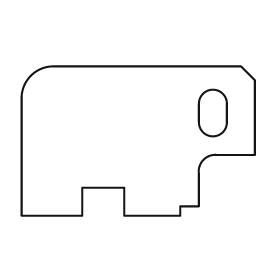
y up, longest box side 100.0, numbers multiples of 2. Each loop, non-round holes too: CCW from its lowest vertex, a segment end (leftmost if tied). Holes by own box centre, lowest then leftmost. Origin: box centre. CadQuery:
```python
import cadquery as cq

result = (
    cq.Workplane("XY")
    .moveTo(-50.0, -32.0)
    .lineTo(-24.0, -32.0)
    .lineTo(-24.0, -20.0)
    .lineTo(-6.0, -20.0)
    .lineTo(-6.0, -32.0)
    .lineTo(18.0, -32.0)
    .lineTo(18.0, -28.0)
    .lineTo(26.0, -28.0)
    .lineTo(26.0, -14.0)
    .threePointArc((28.0, -8.0), (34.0, -6.0))
    .lineTo(50.0, -6.0)
    .lineTo(50.0, 26.0)
    .lineTo(44.0, 32.0)
    .lineTo(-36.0, 32.0)
    .threePointArc((-46.0, 28.0), (-50.0, 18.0))
    .close()
    .moveTo(26.0, 8.0)
    .threePointArc((32.0, 2.0), (38.0, 8.0))
    .lineTo(38.0, 16.0)
    .threePointArc((32.0, 22.0), (26.0, 16.0))
    .close()
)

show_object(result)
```